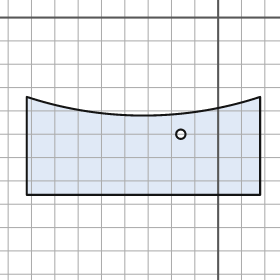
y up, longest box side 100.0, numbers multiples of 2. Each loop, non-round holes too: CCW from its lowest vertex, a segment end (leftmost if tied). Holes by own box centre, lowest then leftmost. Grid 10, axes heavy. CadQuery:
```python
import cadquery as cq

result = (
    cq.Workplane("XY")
    .moveTo(-82.0, -76.0)
    .lineTo(18.0, -76.0)
    .lineTo(18.0, -34.0)
    .threePointArc((-32.0, -42.0), (-82.0, -34.0))
    .close()
    .moveTo(-16.0, -50.0)
    .circle(2.0)
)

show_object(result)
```